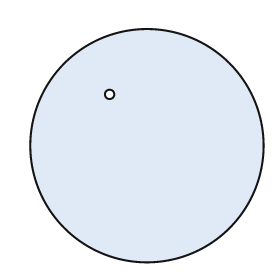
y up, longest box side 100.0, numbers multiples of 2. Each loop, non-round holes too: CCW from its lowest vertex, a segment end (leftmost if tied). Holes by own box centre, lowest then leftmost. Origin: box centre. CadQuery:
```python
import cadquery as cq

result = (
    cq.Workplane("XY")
    .moveTo(0.0, 0.0)
    .circle(50.0)
    .moveTo(-16.0, 22.0)
    .circle(2.0)
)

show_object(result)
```